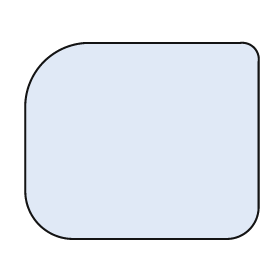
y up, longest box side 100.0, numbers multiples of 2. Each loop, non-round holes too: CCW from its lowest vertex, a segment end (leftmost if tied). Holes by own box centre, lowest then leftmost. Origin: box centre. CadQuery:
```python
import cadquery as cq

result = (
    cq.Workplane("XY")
    .moveTo(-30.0, -42.0)
    .lineTo(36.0, -42.0)
    .threePointArc((46.0, -38.0), (50.0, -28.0))
    .lineTo(50.0, 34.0)
    .threePointArc((48.0, 40.0), (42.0, 42.0))
    .lineTo(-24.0, 42.0)
    .threePointArc((-42.0, 34.0), (-50.0, 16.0))
    .lineTo(-50.0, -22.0)
    .threePointArc((-44.0, -36.0), (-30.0, -42.0))
    .close()
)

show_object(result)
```